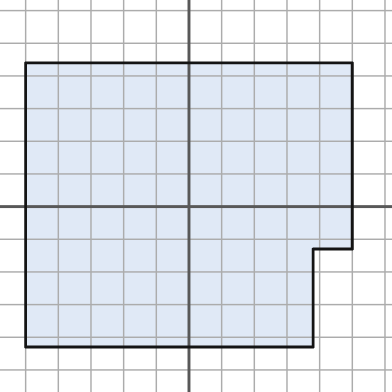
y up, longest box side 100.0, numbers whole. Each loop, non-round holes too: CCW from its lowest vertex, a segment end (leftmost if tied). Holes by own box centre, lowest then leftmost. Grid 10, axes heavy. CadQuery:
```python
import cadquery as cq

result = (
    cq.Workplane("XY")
    .moveTo(-50.0, -43.0)
    .lineTo(38.0, -43.0)
    .lineTo(38.0, -13.0)
    .lineTo(50.0, -13.0)
    .lineTo(50.0, 44.0)
    .lineTo(-50.0, 44.0)
    .close()
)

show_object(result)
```